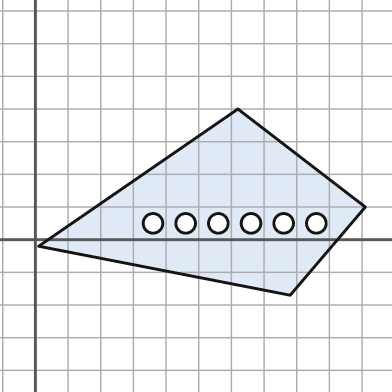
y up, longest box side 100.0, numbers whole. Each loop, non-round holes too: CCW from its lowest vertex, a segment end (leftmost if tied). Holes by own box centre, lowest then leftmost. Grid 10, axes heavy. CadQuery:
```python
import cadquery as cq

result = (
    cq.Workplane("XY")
    .moveTo(78.0, -17.0)
    .lineTo(101.0, 10.0)
    .lineTo(62.0, 40.0)
    .lineTo(1.0, -2.0)
    .close()
    .moveTo(36.0, 5.0)
    .circle(3.0)
    .moveTo(46.0, 5.0)
    .circle(3.0)
    .moveTo(56.0, 5.0)
    .circle(3.0)
    .moveTo(66.0, 5.0)
    .circle(3.0)
    .moveTo(76.0, 5.0)
    .circle(3.0)
    .moveTo(86.0, 5.0)
    .circle(3.0)
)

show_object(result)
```